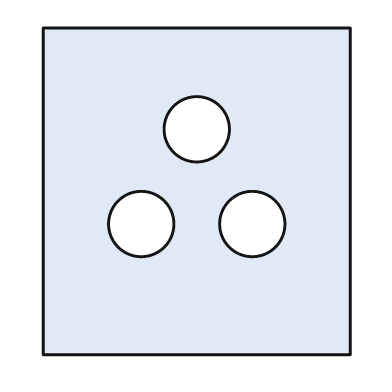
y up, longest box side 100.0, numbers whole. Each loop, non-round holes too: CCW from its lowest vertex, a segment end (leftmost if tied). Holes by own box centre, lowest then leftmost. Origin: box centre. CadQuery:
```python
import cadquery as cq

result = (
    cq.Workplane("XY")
    .moveTo(-47.0, -50.0)
    .lineTo(47.0, -50.0)
    .lineTo(47.0, 50.0)
    .lineTo(-47.0, 50.0)
    .close()
    .moveTo(-17.0, -10.0)
    .circle(10.0)
    .moveTo(17.0, -10.0)
    .circle(10.0)
    .moveTo(0.0, 19.0)
    .circle(10.0)
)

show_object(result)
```